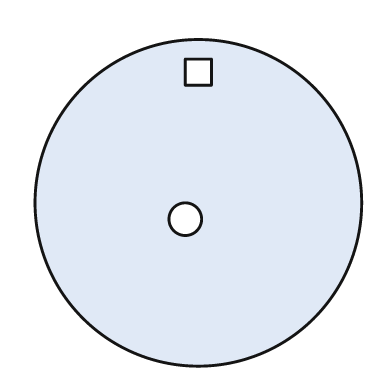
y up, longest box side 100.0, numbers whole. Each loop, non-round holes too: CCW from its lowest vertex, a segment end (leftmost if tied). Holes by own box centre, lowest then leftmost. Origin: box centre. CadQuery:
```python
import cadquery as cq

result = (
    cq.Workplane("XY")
    .moveTo(0.0, 0.0)
    .circle(50.0)
    .moveTo(-4.0, -5.0)
    .circle(5.0)
    .moveTo(-4.0, 36.0)
    .lineTo(4.0, 36.0)
    .lineTo(4.0, 44.0)
    .lineTo(-4.0, 44.0)
    .close()
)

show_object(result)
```